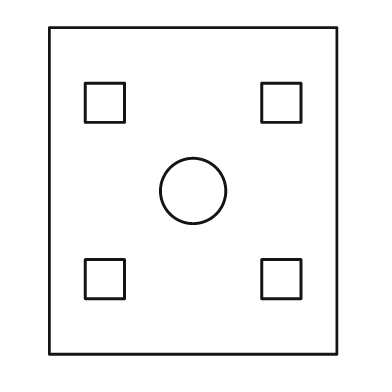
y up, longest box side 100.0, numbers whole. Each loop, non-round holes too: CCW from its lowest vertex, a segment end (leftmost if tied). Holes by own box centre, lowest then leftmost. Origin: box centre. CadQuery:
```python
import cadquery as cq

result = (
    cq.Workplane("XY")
    .moveTo(-44.0, -50.0)
    .lineTo(44.0, -50.0)
    .lineTo(44.0, 50.0)
    .lineTo(-44.0, 50.0)
    .close()
    .moveTo(-33.0, -33.0)
    .lineTo(-21.0, -33.0)
    .lineTo(-21.0, -21.0)
    .lineTo(-33.0, -21.0)
    .close()
    .moveTo(21.0, -33.0)
    .lineTo(33.0, -33.0)
    .lineTo(33.0, -21.0)
    .lineTo(21.0, -21.0)
    .close()
    .moveTo(0.0, 0.0)
    .circle(10.0)
    .moveTo(-33.0, 21.0)
    .lineTo(-21.0, 21.0)
    .lineTo(-21.0, 33.0)
    .lineTo(-33.0, 33.0)
    .close()
    .moveTo(21.0, 21.0)
    .lineTo(33.0, 21.0)
    .lineTo(33.0, 33.0)
    .lineTo(21.0, 33.0)
    .close()
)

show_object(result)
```